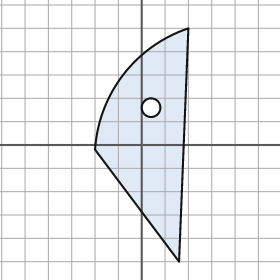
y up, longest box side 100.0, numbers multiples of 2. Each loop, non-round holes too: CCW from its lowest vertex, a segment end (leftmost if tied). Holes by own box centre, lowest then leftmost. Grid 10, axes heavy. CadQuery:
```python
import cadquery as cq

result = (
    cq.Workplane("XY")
    .moveTo(16.0, -50.0)
    .lineTo(20.0, 50.0)
    .threePointArc((-8.0, 30.0), (-20.0, -2.0))
    .close()
    .moveTo(4.0, 16.0)
    .circle(4.0)
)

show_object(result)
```